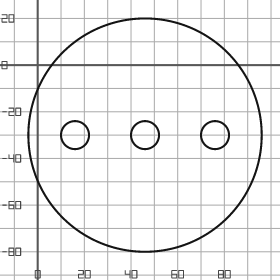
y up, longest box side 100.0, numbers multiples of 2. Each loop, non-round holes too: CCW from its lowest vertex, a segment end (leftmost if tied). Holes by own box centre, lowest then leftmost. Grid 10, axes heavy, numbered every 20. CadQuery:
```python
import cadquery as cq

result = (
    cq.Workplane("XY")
    .moveTo(46.0, -30.0)
    .circle(50.0)
    .moveTo(16.0, -30.0)
    .circle(6.0)
    .moveTo(46.0, -30.0)
    .circle(6.0)
    .moveTo(76.0, -30.0)
    .circle(6.0)
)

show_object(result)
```